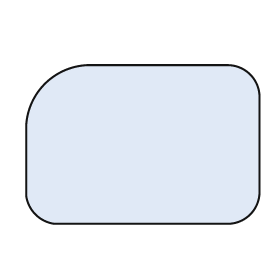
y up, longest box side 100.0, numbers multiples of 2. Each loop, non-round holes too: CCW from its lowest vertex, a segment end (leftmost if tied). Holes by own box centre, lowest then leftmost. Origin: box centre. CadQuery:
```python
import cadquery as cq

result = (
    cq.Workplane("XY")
    .moveTo(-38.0, -34.0)
    .lineTo(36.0, -34.0)
    .threePointArc((46.0, -30.0), (50.0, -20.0))
    .lineTo(50.0, 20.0)
    .threePointArc((46.0, 30.0), (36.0, 34.0))
    .lineTo(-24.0, 34.0)
    .threePointArc((-42.0, 26.0), (-50.0, 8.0))
    .lineTo(-50.0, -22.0)
    .threePointArc((-46.0, -30.0), (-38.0, -34.0))
    .close()
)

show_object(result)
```